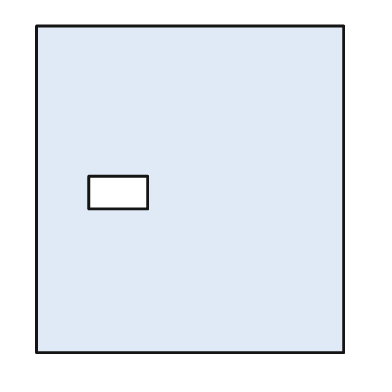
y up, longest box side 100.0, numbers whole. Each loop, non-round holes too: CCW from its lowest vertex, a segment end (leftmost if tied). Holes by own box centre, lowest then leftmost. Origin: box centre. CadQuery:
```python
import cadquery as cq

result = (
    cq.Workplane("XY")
    .moveTo(-47.0, -50.0)
    .lineTo(47.0, -50.0)
    .lineTo(47.0, 50.0)
    .lineTo(-47.0, 50.0)
    .close()
    .moveTo(-31.0, -6.0)
    .lineTo(-13.0, -6.0)
    .lineTo(-13.0, 4.0)
    .lineTo(-31.0, 4.0)
    .close()
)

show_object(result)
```